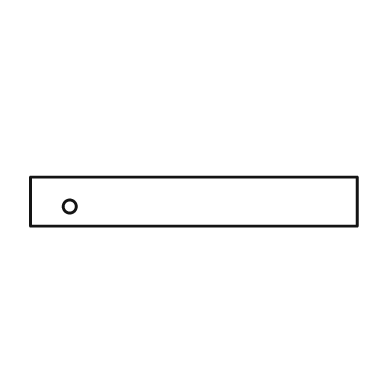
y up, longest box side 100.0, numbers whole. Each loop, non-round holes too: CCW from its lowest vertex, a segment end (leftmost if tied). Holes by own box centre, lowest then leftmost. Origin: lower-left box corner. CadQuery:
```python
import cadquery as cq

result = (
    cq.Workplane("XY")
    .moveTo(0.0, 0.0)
    .lineTo(100.0, 0.0)
    .lineTo(100.0, 15.0)
    .lineTo(0.0, 15.0)
    .close()
    .moveTo(12.0, 6.0)
    .circle(2.0)
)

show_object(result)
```